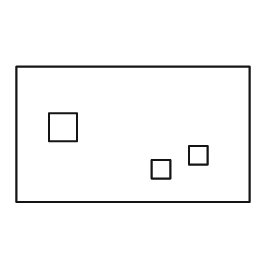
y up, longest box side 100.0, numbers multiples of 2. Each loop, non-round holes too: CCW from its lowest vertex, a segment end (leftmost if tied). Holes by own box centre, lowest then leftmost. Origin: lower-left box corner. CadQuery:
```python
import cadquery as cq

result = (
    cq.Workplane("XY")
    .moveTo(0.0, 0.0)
    .lineTo(100.0, 0.0)
    .lineTo(100.0, 58.0)
    .lineTo(0.0, 58.0)
    .close()
    .moveTo(58.0, 10.0)
    .lineTo(66.0, 10.0)
    .lineTo(66.0, 18.0)
    .lineTo(58.0, 18.0)
    .close()
    .moveTo(74.0, 16.0)
    .lineTo(82.0, 16.0)
    .lineTo(82.0, 24.0)
    .lineTo(74.0, 24.0)
    .close()
    .moveTo(14.0, 26.0)
    .lineTo(26.0, 26.0)
    .lineTo(26.0, 38.0)
    .lineTo(14.0, 38.0)
    .close()
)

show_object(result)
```